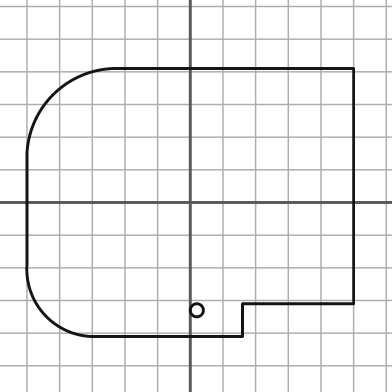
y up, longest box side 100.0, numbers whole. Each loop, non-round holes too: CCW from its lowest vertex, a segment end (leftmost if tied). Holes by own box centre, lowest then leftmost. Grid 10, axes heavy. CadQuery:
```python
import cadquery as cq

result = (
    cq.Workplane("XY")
    .moveTo(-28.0, -41.0)
    .lineTo(16.0, -41.0)
    .lineTo(16.0, -31.0)
    .lineTo(50.0, -31.0)
    .lineTo(50.0, 41.0)
    .lineTo(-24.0, 41.0)
    .threePointArc((-42.0, 33.0), (-50.0, 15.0))
    .lineTo(-50.0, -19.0)
    .threePointArc((-44.0, -35.0), (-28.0, -41.0))
    .close()
    .moveTo(2.0, -33.0)
    .circle(2.0)
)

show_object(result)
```